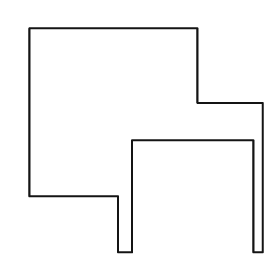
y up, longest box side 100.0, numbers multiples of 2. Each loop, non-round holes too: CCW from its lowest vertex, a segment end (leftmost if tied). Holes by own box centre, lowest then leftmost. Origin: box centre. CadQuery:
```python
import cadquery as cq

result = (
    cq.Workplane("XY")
    .moveTo(-12.0, -48.0)
    .lineTo(-6.0, -48.0)
    .lineTo(-6.0, 0.0)
    .lineTo(46.0, 0.0)
    .lineTo(46.0, -48.0)
    .lineTo(50.0, -48.0)
    .lineTo(50.0, 16.0)
    .lineTo(22.0, 16.0)
    .lineTo(22.0, 48.0)
    .lineTo(-50.0, 48.0)
    .lineTo(-50.0, -24.0)
    .lineTo(-12.0, -24.0)
    .close()
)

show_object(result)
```